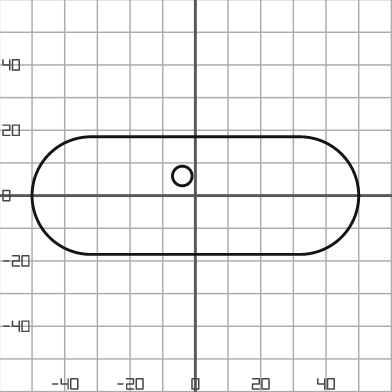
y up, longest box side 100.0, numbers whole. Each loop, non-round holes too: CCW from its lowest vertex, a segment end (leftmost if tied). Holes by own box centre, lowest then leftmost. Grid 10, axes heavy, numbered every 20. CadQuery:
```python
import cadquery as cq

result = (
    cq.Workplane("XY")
    .moveTo(-32.0, -18.0)
    .lineTo(32.0, -18.0)
    .threePointArc((50.0, 0.0), (32.0, 18.0))
    .lineTo(-32.0, 18.0)
    .threePointArc((-50.0, 0.0), (-32.0, -18.0))
    .close()
    .moveTo(-4.0, 6.0)
    .circle(3.0)
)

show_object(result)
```